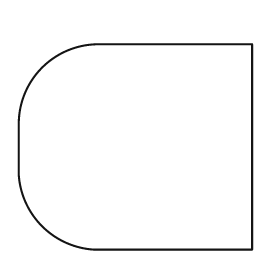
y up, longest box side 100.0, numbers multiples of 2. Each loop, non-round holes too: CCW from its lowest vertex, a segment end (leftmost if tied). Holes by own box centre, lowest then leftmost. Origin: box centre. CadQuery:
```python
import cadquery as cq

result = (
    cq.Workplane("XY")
    .moveTo(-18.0, -44.0)
    .lineTo(50.0, -44.0)
    .lineTo(50.0, 44.0)
    .lineTo(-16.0, 44.0)
    .threePointArc((-40.0, 34.0), (-50.0, 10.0))
    .lineTo(-50.0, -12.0)
    .threePointArc((-40.0, -34.0), (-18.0, -44.0))
    .close()
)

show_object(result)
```